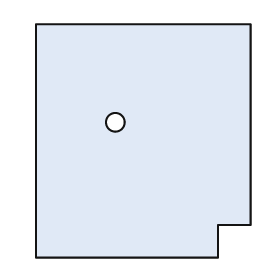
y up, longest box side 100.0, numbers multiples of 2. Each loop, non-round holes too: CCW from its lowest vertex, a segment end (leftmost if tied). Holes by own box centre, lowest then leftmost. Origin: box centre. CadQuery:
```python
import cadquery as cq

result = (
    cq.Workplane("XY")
    .moveTo(-46.0, -50.0)
    .lineTo(32.0, -50.0)
    .lineTo(32.0, -36.0)
    .lineTo(46.0, -36.0)
    .lineTo(46.0, 50.0)
    .lineTo(-46.0, 50.0)
    .close()
    .moveTo(-12.0, 8.0)
    .circle(4.0)
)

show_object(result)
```